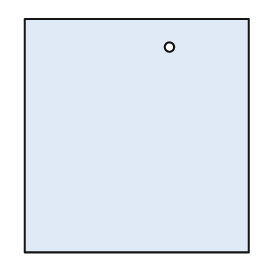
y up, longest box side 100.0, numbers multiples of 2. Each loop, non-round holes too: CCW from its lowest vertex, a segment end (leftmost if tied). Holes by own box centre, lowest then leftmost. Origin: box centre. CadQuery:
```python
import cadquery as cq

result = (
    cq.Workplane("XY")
    .moveTo(-48.0, -50.0)
    .lineTo(48.0, -50.0)
    .lineTo(48.0, 50.0)
    .lineTo(-48.0, 50.0)
    .close()
    .moveTo(14.0, 38.0)
    .circle(2.0)
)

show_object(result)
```